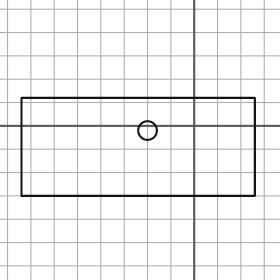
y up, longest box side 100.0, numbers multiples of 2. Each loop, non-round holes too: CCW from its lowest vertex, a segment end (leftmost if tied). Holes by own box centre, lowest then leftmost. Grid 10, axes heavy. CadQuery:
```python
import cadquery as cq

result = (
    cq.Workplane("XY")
    .moveTo(-74.0, -30.0)
    .lineTo(26.0, -30.0)
    .lineTo(26.0, 12.0)
    .lineTo(-74.0, 12.0)
    .close()
    .moveTo(-20.0, -2.0)
    .circle(4.0)
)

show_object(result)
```